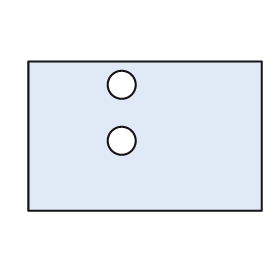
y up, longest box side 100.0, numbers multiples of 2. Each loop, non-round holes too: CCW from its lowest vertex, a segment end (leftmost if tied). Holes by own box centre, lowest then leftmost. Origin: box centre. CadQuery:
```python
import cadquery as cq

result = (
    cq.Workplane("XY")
    .moveTo(-50.0, -32.0)
    .lineTo(50.0, -32.0)
    .lineTo(50.0, 32.0)
    .lineTo(-50.0, 32.0)
    .close()
    .moveTo(-10.0, -2.0)
    .circle(6.0)
    .moveTo(-10.0, 22.0)
    .circle(6.0)
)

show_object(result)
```